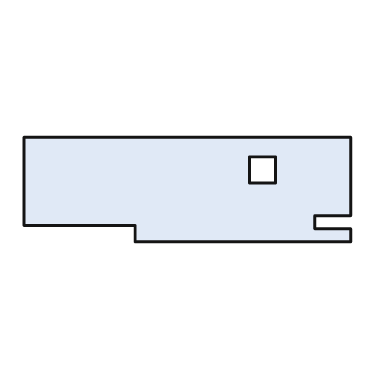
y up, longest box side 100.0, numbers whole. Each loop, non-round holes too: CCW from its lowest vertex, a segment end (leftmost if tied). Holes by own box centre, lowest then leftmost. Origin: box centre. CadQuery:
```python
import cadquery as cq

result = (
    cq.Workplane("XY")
    .moveTo(-16.0, -16.0)
    .lineTo(50.0, -16.0)
    .lineTo(50.0, -12.0)
    .lineTo(39.0, -12.0)
    .lineTo(39.0, -8.0)
    .lineTo(50.0, -8.0)
    .lineTo(50.0, 16.0)
    .lineTo(-50.0, 16.0)
    .lineTo(-50.0, -11.0)
    .lineTo(-16.0, -11.0)
    .close()
    .moveTo(19.0, 2.0)
    .lineTo(27.0, 2.0)
    .lineTo(27.0, 10.0)
    .lineTo(19.0, 10.0)
    .close()
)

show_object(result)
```